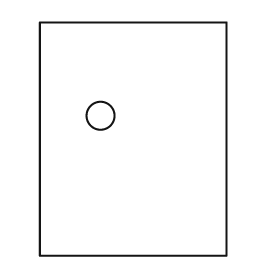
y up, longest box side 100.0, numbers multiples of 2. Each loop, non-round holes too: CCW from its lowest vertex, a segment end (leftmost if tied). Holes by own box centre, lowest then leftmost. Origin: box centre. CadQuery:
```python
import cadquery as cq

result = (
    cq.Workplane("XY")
    .moveTo(-40.0, -50.0)
    .lineTo(40.0, -50.0)
    .lineTo(40.0, 50.0)
    .lineTo(-40.0, 50.0)
    .close()
    .moveTo(-14.0, 10.0)
    .circle(6.0)
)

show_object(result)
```